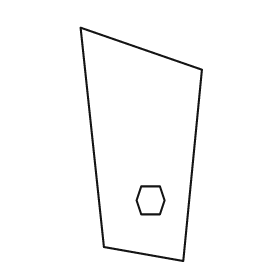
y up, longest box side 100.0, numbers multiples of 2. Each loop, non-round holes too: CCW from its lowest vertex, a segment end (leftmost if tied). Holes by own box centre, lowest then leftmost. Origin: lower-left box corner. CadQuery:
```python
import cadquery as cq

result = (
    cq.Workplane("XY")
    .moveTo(44.0, 0.0)
    .lineTo(52.0, 82.0)
    .lineTo(0.0, 100.0)
    .lineTo(10.0, 6.0)
    .close()
    .moveTo(26.0, 20.0)
    .lineTo(34.0, 20.0)
    .lineTo(36.0, 26.0)
    .lineTo(34.0, 32.0)
    .lineTo(26.0, 32.0)
    .lineTo(24.0, 26.0)
    .close()
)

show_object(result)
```